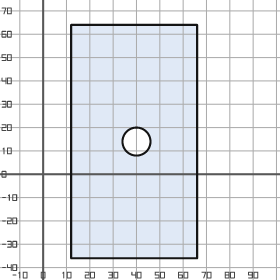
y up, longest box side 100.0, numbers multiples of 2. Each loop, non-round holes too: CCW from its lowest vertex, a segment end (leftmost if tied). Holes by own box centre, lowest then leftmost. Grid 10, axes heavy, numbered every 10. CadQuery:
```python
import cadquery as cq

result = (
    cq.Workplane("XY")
    .moveTo(12.0, -36.0)
    .lineTo(66.0, -36.0)
    .lineTo(66.0, 64.0)
    .lineTo(12.0, 64.0)
    .close()
    .moveTo(40.0, 14.0)
    .circle(6.0)
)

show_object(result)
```